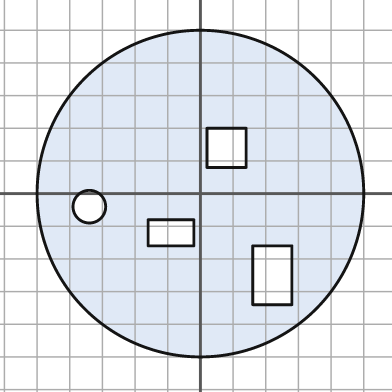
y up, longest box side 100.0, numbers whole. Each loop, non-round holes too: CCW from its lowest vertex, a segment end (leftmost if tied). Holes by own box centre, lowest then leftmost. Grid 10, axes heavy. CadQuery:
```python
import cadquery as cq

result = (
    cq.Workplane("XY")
    .moveTo(0.0, 0.0)
    .circle(50.0)
    .moveTo(16.0, -34.0)
    .lineTo(28.0, -34.0)
    .lineTo(28.0, -16.0)
    .lineTo(16.0, -16.0)
    .close()
    .moveTo(-16.0, -16.0)
    .lineTo(-2.0, -16.0)
    .lineTo(-2.0, -8.0)
    .lineTo(-16.0, -8.0)
    .close()
    .moveTo(-34.0, -4.0)
    .circle(5.0)
    .moveTo(2.0, 8.0)
    .lineTo(14.0, 8.0)
    .lineTo(14.0, 20.0)
    .lineTo(2.0, 20.0)
    .close()
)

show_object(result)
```